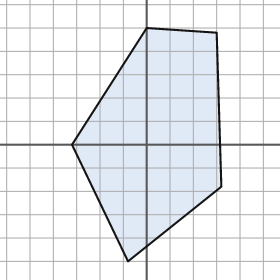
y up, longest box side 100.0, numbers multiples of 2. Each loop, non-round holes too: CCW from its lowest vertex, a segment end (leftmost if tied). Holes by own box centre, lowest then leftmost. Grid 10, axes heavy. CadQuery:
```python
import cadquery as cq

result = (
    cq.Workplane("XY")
    .moveTo(-8.0, -50.0)
    .lineTo(32.0, -18.0)
    .lineTo(30.0, 48.0)
    .lineTo(0.0, 50.0)
    .lineTo(-32.0, 0.0)
    .close()
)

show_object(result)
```